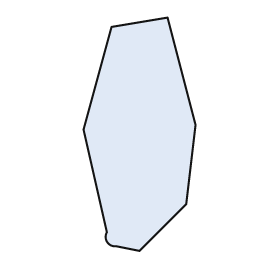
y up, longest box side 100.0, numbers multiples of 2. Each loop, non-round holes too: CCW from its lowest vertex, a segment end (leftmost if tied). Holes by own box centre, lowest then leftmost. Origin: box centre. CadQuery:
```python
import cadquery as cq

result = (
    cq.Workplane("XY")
    .moveTo(0.0, -50.0)
    .lineTo(20.0, -30.0)
    .lineTo(24.0, 4.0)
    .lineTo(12.0, 50.0)
    .lineTo(-12.0, 46.0)
    .lineTo(-24.0, 2.0)
    .lineTo(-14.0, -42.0)
    .threePointArc((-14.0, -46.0), (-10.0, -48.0))
    .close()
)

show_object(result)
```